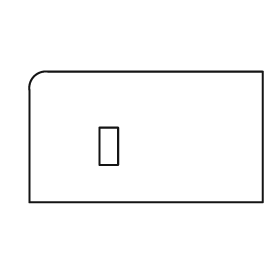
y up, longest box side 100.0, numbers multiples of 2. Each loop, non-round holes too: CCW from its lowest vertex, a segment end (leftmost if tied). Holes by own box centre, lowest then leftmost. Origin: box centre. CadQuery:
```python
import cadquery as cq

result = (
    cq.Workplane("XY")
    .moveTo(-50.0, -28.0)
    .lineTo(50.0, -28.0)
    .lineTo(50.0, 28.0)
    .lineTo(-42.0, 28.0)
    .threePointArc((-48.0, 26.0), (-50.0, 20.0))
    .close()
    .moveTo(-20.0, -12.0)
    .lineTo(-12.0, -12.0)
    .lineTo(-12.0, 4.0)
    .lineTo(-20.0, 4.0)
    .close()
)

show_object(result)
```